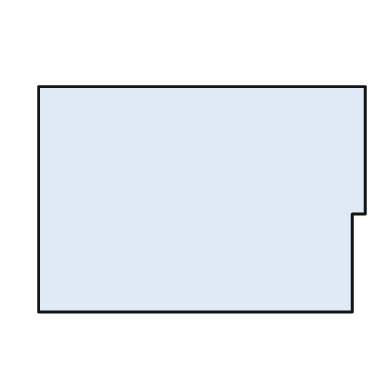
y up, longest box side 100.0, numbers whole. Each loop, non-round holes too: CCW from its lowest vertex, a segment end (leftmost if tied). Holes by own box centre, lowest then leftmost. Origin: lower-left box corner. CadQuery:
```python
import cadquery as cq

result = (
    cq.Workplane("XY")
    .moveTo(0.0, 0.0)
    .lineTo(96.0, 0.0)
    .lineTo(96.0, 30.0)
    .lineTo(100.0, 30.0)
    .lineTo(100.0, 69.0)
    .lineTo(0.0, 69.0)
    .close()
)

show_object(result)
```